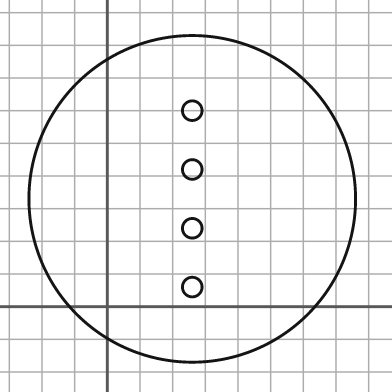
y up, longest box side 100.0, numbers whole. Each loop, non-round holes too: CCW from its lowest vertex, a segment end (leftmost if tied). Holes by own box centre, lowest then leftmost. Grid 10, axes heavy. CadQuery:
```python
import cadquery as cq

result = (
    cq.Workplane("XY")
    .moveTo(26.0, 33.0)
    .circle(50.0)
    .moveTo(26.0, 6.0)
    .circle(3.0)
    .moveTo(26.0, 24.0)
    .circle(3.0)
    .moveTo(26.0, 42.0)
    .circle(3.0)
    .moveTo(26.0, 60.0)
    .circle(3.0)
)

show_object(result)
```